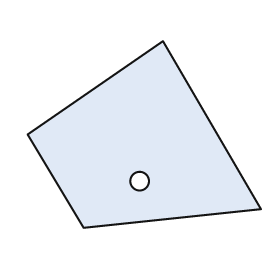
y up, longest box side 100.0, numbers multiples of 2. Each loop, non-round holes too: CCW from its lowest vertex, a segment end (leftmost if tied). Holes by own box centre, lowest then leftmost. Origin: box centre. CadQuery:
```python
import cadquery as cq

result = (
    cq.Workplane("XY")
    .moveTo(-26.0, -40.0)
    .lineTo(50.0, -32.0)
    .lineTo(8.0, 40.0)
    .lineTo(-50.0, 0.0)
    .close()
    .moveTo(-2.0, -20.0)
    .circle(4.0)
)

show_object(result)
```